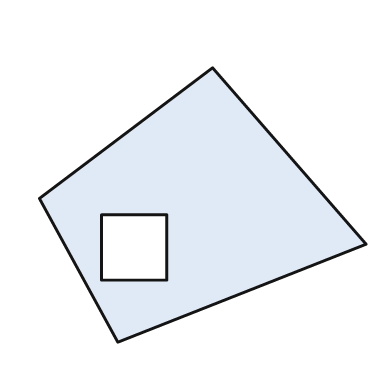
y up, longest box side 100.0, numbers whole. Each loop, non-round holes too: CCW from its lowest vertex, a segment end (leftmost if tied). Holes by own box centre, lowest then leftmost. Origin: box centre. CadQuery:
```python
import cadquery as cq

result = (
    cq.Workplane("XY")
    .moveTo(-26.0, -42.0)
    .lineTo(50.0, -12.0)
    .lineTo(3.0, 42.0)
    .lineTo(-50.0, 2.0)
    .close()
    .moveTo(-31.0, -23.0)
    .lineTo(-11.0, -23.0)
    .lineTo(-11.0, -3.0)
    .lineTo(-31.0, -3.0)
    .close()
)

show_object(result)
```